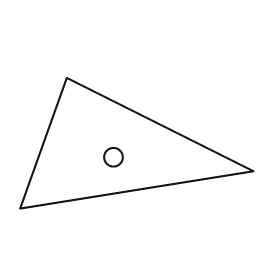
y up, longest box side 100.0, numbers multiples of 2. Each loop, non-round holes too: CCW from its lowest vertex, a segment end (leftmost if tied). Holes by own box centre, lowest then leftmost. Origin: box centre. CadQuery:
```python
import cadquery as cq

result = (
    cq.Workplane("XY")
    .moveTo(-50.0, -28.0)
    .lineTo(50.0, -12.0)
    .lineTo(-30.0, 28.0)
    .close()
    .moveTo(-10.0, -6.0)
    .circle(4.0)
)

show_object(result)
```